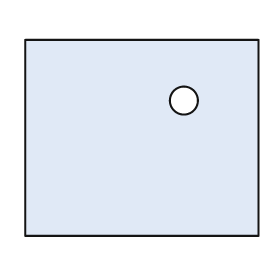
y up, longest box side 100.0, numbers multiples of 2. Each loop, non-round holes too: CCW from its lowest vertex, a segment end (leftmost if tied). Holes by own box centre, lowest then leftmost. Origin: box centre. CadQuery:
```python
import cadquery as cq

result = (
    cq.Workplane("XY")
    .moveTo(-50.0, -42.0)
    .lineTo(50.0, -42.0)
    .lineTo(50.0, 42.0)
    .lineTo(-50.0, 42.0)
    .close()
    .moveTo(18.0, 16.0)
    .circle(6.0)
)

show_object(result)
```